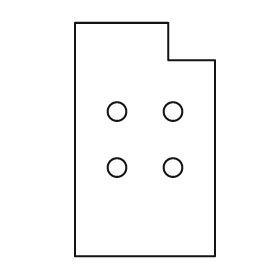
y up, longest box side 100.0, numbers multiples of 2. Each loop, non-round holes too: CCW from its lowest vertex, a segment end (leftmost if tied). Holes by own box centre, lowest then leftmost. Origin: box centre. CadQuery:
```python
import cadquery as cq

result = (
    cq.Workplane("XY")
    .moveTo(-30.0, -50.0)
    .lineTo(30.0, -50.0)
    .lineTo(30.0, 34.0)
    .lineTo(10.0, 34.0)
    .lineTo(10.0, 50.0)
    .lineTo(-30.0, 50.0)
    .close()
    .moveTo(-12.0, -12.0)
    .circle(4.0)
    .moveTo(12.0, -12.0)
    .circle(4.0)
    .moveTo(-12.0, 12.0)
    .circle(4.0)
    .moveTo(12.0, 12.0)
    .circle(4.0)
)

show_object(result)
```